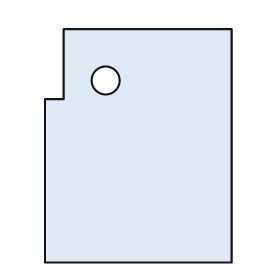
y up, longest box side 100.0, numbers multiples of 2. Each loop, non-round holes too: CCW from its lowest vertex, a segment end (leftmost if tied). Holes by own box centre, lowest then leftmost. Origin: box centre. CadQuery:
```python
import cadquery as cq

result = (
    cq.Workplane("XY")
    .moveTo(-40.0, -50.0)
    .lineTo(40.0, -50.0)
    .lineTo(40.0, 50.0)
    .lineTo(-32.0, 50.0)
    .lineTo(-32.0, 20.0)
    .lineTo(-40.0, 20.0)
    .close()
    .moveTo(-14.0, 28.0)
    .circle(6.0)
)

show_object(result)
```